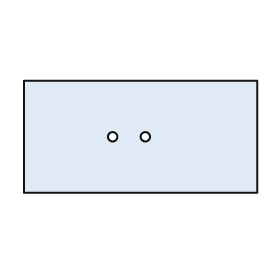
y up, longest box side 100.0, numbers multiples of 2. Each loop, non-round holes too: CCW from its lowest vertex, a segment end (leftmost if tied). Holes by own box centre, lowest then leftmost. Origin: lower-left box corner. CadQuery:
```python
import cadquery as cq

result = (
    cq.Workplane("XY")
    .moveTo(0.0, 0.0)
    .lineTo(100.0, 0.0)
    .lineTo(100.0, 48.0)
    .lineTo(0.0, 48.0)
    .close()
    .moveTo(38.0, 24.0)
    .circle(2.0)
    .moveTo(52.0, 24.0)
    .circle(2.0)
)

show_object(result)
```